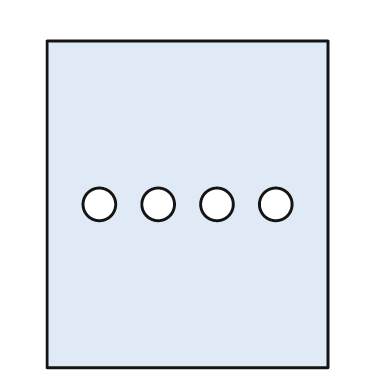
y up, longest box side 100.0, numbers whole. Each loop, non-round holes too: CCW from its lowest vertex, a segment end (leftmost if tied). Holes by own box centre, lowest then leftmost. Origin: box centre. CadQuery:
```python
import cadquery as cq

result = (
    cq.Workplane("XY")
    .moveTo(-43.0, -50.0)
    .lineTo(43.0, -50.0)
    .lineTo(43.0, 50.0)
    .lineTo(-43.0, 50.0)
    .close()
    .moveTo(-27.0, 0.0)
    .circle(5.0)
    .moveTo(-9.0, 0.0)
    .circle(5.0)
    .moveTo(9.0, 0.0)
    .circle(5.0)
    .moveTo(27.0, 0.0)
    .circle(5.0)
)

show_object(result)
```